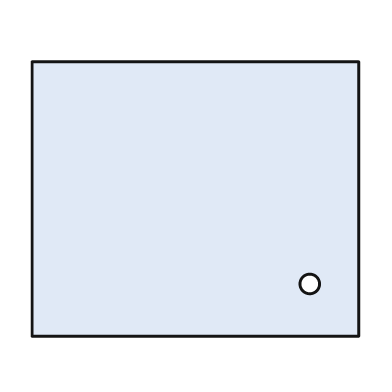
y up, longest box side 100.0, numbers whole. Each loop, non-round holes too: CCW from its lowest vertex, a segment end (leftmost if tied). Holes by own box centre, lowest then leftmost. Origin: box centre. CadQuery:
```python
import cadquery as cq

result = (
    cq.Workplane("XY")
    .moveTo(-50.0, -42.0)
    .lineTo(50.0, -42.0)
    .lineTo(50.0, 42.0)
    .lineTo(-50.0, 42.0)
    .close()
    .moveTo(35.0, -26.0)
    .circle(3.0)
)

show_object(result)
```